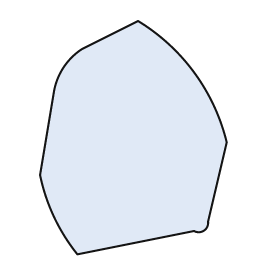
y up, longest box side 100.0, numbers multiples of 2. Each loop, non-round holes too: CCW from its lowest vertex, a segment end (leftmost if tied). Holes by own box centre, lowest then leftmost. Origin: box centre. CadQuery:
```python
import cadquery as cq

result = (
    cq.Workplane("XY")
    .moveTo(-24.0, -50.0)
    .lineTo(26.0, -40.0)
    .threePointArc((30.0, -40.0), (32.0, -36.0))
    .lineTo(40.0, -2.0)
    .threePointArc((26.0, 28.0), (2.0, 50.0))
    .lineTo(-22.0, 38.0)
    .threePointArc((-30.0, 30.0), (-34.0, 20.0))
    .lineTo(-40.0, -16.0)
    .threePointArc((-34.0, -34.0), (-24.0, -50.0))
    .close()
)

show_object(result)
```